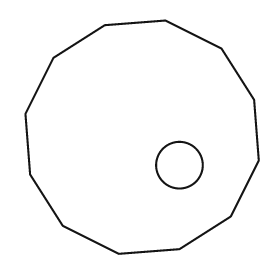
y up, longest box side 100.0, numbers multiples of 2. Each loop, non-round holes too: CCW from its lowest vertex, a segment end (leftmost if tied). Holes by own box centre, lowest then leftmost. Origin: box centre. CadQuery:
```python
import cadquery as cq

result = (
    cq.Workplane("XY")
    .moveTo(-10.0, -50.0)
    .lineTo(16.0, -48.0)
    .lineTo(38.0, -34.0)
    .lineTo(50.0, -10.0)
    .lineTo(48.0, 16.0)
    .lineTo(34.0, 38.0)
    .lineTo(10.0, 50.0)
    .lineTo(-16.0, 48.0)
    .lineTo(-38.0, 34.0)
    .lineTo(-50.0, 10.0)
    .lineTo(-48.0, -16.0)
    .lineTo(-34.0, -38.0)
    .close()
    .moveTo(16.0, -12.0)
    .circle(10.0)
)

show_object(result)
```